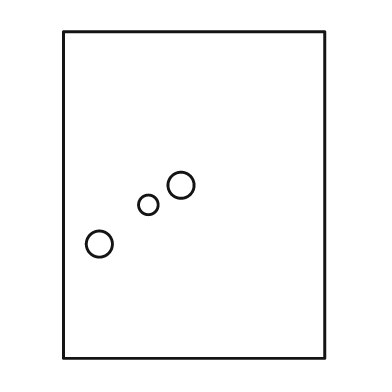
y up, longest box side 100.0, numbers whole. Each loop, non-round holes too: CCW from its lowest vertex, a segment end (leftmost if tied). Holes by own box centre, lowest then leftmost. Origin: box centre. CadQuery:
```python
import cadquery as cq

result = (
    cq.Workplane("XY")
    .moveTo(-40.0, -50.0)
    .lineTo(40.0, -50.0)
    .lineTo(40.0, 50.0)
    .lineTo(-40.0, 50.0)
    .close()
    .moveTo(-29.0, -15.0)
    .circle(4.0)
    .moveTo(-14.0, -3.0)
    .circle(3.0)
    .moveTo(-4.0, 3.0)
    .circle(4.0)
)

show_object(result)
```